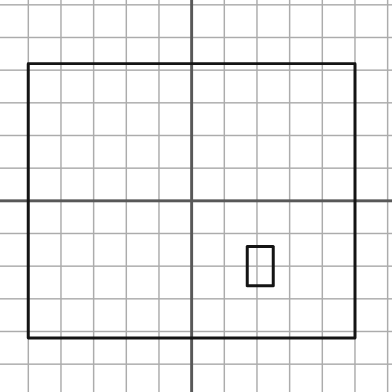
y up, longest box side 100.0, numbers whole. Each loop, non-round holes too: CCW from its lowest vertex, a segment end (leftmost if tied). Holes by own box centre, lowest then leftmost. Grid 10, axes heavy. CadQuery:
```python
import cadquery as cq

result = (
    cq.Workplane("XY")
    .moveTo(-50.0, -42.0)
    .lineTo(50.0, -42.0)
    .lineTo(50.0, 42.0)
    .lineTo(-50.0, 42.0)
    .close()
    .moveTo(17.0, -26.0)
    .lineTo(25.0, -26.0)
    .lineTo(25.0, -14.0)
    .lineTo(17.0, -14.0)
    .close()
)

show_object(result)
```